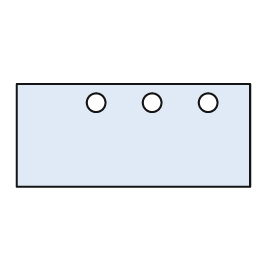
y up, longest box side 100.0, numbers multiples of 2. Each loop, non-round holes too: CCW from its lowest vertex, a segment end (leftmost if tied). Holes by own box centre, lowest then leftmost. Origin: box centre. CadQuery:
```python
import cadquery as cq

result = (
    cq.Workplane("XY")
    .moveTo(-50.0, -22.0)
    .lineTo(50.0, -22.0)
    .lineTo(50.0, 22.0)
    .lineTo(-50.0, 22.0)
    .close()
    .moveTo(-16.0, 14.0)
    .circle(4.0)
    .moveTo(8.0, 14.0)
    .circle(4.0)
    .moveTo(32.0, 14.0)
    .circle(4.0)
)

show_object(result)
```